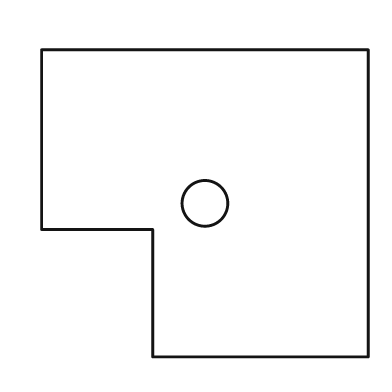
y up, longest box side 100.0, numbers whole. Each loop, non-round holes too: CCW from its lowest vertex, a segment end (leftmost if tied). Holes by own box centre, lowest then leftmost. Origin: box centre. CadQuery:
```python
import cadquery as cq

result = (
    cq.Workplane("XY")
    .moveTo(-16.0, -47.0)
    .lineTo(50.0, -47.0)
    .lineTo(50.0, 47.0)
    .lineTo(-50.0, 47.0)
    .lineTo(-50.0, -8.0)
    .lineTo(-16.0, -8.0)
    .close()
    .moveTo(0.0, 0.0)
    .circle(7.0)
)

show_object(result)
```